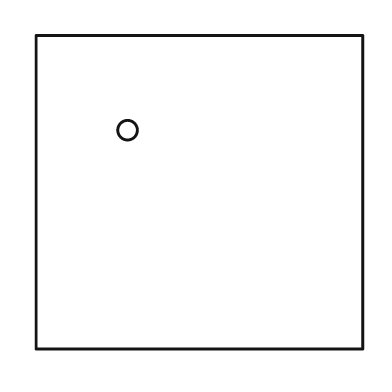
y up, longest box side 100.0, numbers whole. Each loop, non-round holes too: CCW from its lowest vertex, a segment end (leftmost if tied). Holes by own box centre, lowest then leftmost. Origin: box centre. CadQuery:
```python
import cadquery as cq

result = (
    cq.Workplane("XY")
    .moveTo(-50.0, -48.0)
    .lineTo(50.0, -48.0)
    .lineTo(50.0, 48.0)
    .lineTo(-50.0, 48.0)
    .close()
    .moveTo(-22.0, 19.0)
    .circle(3.0)
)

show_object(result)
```